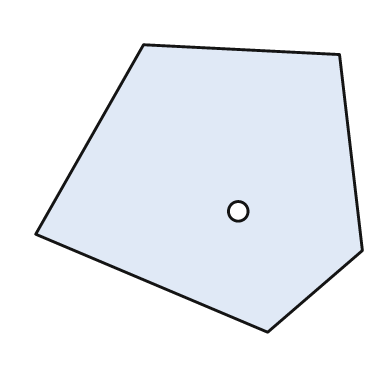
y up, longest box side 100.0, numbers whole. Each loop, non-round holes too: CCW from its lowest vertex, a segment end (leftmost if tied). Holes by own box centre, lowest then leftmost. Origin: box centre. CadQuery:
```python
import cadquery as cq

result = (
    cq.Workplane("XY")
    .moveTo(21.0, -44.0)
    .lineTo(50.0, -19.0)
    .lineTo(43.0, 41.0)
    .lineTo(-17.0, 44.0)
    .lineTo(-50.0, -14.0)
    .close()
    .moveTo(12.0, -7.0)
    .circle(3.0)
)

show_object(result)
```